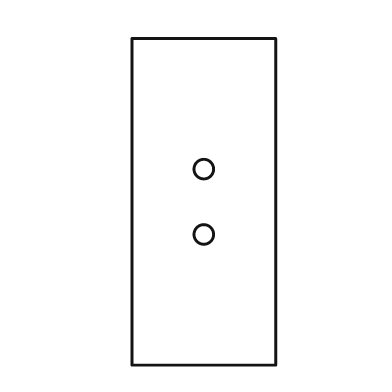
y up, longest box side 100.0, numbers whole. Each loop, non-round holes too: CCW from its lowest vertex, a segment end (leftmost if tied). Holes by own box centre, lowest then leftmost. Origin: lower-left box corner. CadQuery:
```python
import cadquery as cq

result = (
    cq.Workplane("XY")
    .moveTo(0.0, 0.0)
    .lineTo(44.0, 0.0)
    .lineTo(44.0, 100.0)
    .lineTo(0.0, 100.0)
    .close()
    .moveTo(22.0, 40.0)
    .circle(3.0)
    .moveTo(22.0, 60.0)
    .circle(3.0)
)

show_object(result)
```